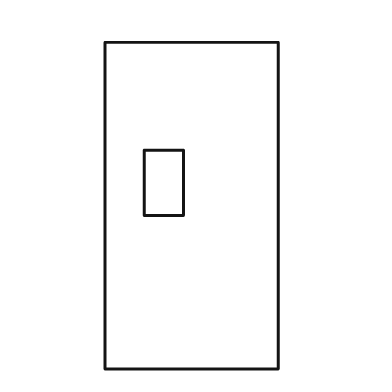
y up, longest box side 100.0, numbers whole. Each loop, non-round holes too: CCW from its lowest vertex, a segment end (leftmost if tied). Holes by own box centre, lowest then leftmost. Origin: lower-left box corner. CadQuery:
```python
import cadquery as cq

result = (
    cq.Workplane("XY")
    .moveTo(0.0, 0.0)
    .lineTo(53.0, 0.0)
    .lineTo(53.0, 100.0)
    .lineTo(0.0, 100.0)
    .close()
    .moveTo(12.0, 47.0)
    .lineTo(24.0, 47.0)
    .lineTo(24.0, 67.0)
    .lineTo(12.0, 67.0)
    .close()
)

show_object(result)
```